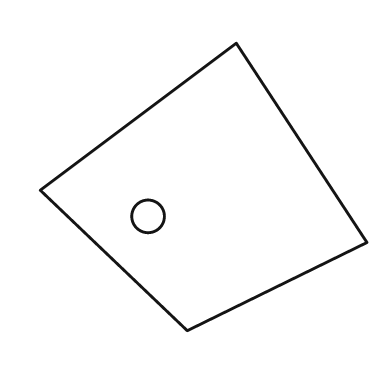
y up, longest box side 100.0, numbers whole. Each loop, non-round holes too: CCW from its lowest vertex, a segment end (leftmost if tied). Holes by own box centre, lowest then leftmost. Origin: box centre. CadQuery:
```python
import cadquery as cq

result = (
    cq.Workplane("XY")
    .moveTo(-5.0, -44.0)
    .lineTo(50.0, -17.0)
    .lineTo(10.0, 44.0)
    .lineTo(-50.0, -1.0)
    .close()
    .moveTo(-17.0, -9.0)
    .circle(5.0)
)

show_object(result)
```